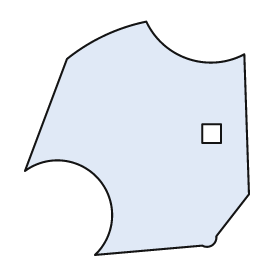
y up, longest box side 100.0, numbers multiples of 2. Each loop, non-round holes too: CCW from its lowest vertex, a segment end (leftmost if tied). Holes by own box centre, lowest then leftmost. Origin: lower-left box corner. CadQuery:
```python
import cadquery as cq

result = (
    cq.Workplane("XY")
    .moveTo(30.0, 0.0)
    .lineTo(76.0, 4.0)
    .threePointArc((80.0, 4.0), (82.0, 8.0))
    .lineTo(96.0, 26.0)
    .lineTo(94.0, 86.0)
    .threePointArc((70.0, 84.0), (52.0, 100.0))
    .threePointArc((34.0, 94.0), (18.0, 84.0))
    .lineTo(0.0, 36.0)
    .threePointArc((32.0, 32.0), (30.0, 0.0))
    .close()
    .moveTo(76.0, 48.0)
    .lineTo(84.0, 48.0)
    .lineTo(84.0, 56.0)
    .lineTo(76.0, 56.0)
    .close()
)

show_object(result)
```